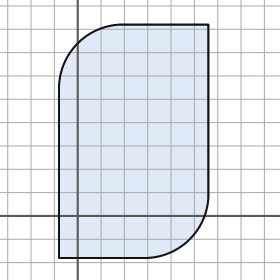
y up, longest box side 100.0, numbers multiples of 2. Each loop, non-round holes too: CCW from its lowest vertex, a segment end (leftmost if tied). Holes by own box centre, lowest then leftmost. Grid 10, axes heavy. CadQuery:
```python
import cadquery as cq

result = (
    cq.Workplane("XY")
    .moveTo(-8.0, -18.0)
    .lineTo(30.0, -18.0)
    .threePointArc((48.0, -10.0), (56.0, 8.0))
    .lineTo(56.0, 82.0)
    .lineTo(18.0, 82.0)
    .threePointArc((0.0, 74.0), (-8.0, 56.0))
    .close()
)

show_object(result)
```